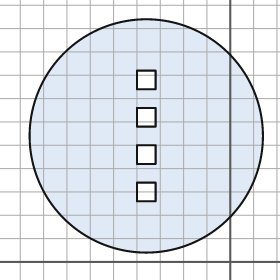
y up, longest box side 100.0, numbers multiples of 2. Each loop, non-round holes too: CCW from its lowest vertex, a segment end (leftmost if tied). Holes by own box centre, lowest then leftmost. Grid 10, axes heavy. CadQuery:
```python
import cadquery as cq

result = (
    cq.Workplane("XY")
    .moveTo(-36.0, 54.0)
    .circle(50.0)
    .moveTo(-40.0, 26.0)
    .lineTo(-32.0, 26.0)
    .lineTo(-32.0, 34.0)
    .lineTo(-40.0, 34.0)
    .close()
    .moveTo(-40.0, 42.0)
    .lineTo(-32.0, 42.0)
    .lineTo(-32.0, 50.0)
    .lineTo(-40.0, 50.0)
    .close()
    .moveTo(-40.0, 58.0)
    .lineTo(-32.0, 58.0)
    .lineTo(-32.0, 66.0)
    .lineTo(-40.0, 66.0)
    .close()
    .moveTo(-40.0, 74.0)
    .lineTo(-32.0, 74.0)
    .lineTo(-32.0, 82.0)
    .lineTo(-40.0, 82.0)
    .close()
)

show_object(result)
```